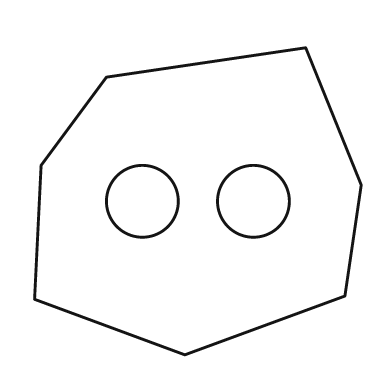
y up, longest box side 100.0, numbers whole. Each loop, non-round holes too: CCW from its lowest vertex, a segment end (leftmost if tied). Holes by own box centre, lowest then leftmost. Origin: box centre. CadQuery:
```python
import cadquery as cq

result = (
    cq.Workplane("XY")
    .moveTo(-4.0, -47.0)
    .lineTo(45.0, -29.0)
    .lineTo(50.0, 5.0)
    .lineTo(33.0, 47.0)
    .lineTo(-28.0, 38.0)
    .lineTo(-48.0, 11.0)
    .lineTo(-50.0, -30.0)
    .close()
    .moveTo(-17.0, 0.0)
    .circle(11.0)
    .moveTo(17.0, 0.0)
    .circle(11.0)
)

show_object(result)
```